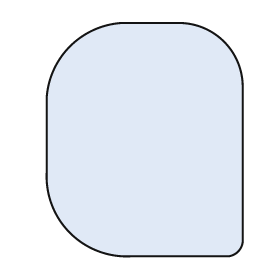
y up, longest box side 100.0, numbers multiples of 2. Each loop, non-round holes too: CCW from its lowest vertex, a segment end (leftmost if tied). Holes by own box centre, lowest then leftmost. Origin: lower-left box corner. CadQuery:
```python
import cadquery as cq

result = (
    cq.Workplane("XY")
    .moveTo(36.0, 0.0)
    .lineTo(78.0, 0.0)
    .threePointArc((82.0, 2.0), (84.0, 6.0))
    .lineTo(84.0, 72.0)
    .threePointArc((76.0, 92.0), (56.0, 100.0))
    .lineTo(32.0, 100.0)
    .threePointArc((10.0, 90.0), (0.0, 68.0))
    .lineTo(0.0, 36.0)
    .threePointArc((10.0, 10.0), (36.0, 0.0))
    .close()
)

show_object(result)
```